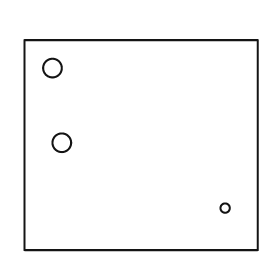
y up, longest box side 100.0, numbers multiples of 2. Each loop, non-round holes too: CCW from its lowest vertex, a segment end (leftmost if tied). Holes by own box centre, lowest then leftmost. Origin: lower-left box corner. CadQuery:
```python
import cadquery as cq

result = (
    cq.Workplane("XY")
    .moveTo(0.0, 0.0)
    .lineTo(100.0, 0.0)
    .lineTo(100.0, 90.0)
    .lineTo(0.0, 90.0)
    .close()
    .moveTo(86.0, 18.0)
    .circle(2.0)
    .moveTo(16.0, 46.0)
    .circle(4.0)
    .moveTo(12.0, 78.0)
    .circle(4.0)
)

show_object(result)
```